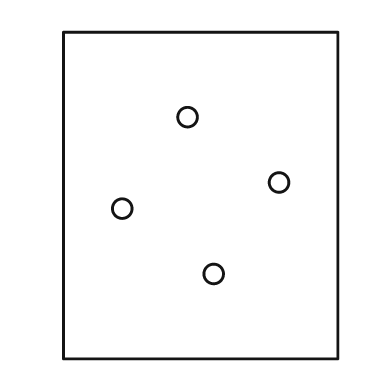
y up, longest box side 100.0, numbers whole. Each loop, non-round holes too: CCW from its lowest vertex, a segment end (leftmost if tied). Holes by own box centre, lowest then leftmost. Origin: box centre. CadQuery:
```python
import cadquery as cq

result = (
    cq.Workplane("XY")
    .moveTo(-42.0, -50.0)
    .lineTo(42.0, -50.0)
    .lineTo(42.0, 50.0)
    .lineTo(-42.0, 50.0)
    .close()
    .moveTo(4.0, -24.0)
    .circle(3.0)
    .moveTo(-24.0, -4.0)
    .circle(3.0)
    .moveTo(24.0, 4.0)
    .circle(3.0)
    .moveTo(-4.0, 24.0)
    .circle(3.0)
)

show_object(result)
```